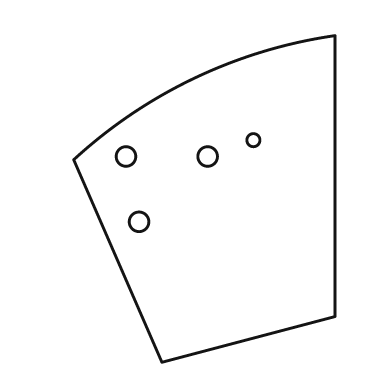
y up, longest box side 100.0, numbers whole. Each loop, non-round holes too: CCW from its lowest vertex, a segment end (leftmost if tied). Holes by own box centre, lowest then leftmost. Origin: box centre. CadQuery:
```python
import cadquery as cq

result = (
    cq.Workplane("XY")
    .moveTo(-13.0, -50.0)
    .lineTo(40.0, -36.0)
    .lineTo(40.0, 50.0)
    .threePointArc((-3.0, 37.0), (-40.0, 12.0))
    .close()
    .moveTo(-20.0, -7.0)
    .circle(3.0)
    .moveTo(-24.0, 13.0)
    .circle(3.0)
    .moveTo(1.0, 13.0)
    .circle(3.0)
    .moveTo(15.0, 18.0)
    .circle(2.0)
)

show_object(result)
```